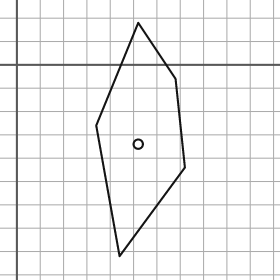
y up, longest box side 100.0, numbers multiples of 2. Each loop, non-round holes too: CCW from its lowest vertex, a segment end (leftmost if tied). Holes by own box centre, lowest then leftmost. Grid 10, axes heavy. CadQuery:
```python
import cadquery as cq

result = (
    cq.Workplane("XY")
    .moveTo(44.0, -82.0)
    .lineTo(72.0, -44.0)
    .lineTo(68.0, -6.0)
    .lineTo(52.0, 18.0)
    .lineTo(34.0, -26.0)
    .close()
    .moveTo(52.0, -34.0)
    .circle(2.0)
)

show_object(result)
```